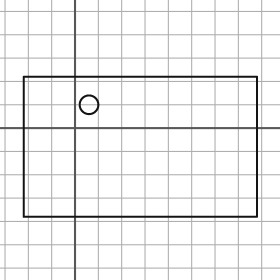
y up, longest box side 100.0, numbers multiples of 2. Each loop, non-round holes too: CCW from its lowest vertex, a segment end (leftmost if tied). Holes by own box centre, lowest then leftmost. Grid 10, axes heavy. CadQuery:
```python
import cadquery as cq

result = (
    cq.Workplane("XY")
    .moveTo(-22.0, -38.0)
    .lineTo(78.0, -38.0)
    .lineTo(78.0, 22.0)
    .lineTo(-22.0, 22.0)
    .close()
    .moveTo(6.0, 10.0)
    .circle(4.0)
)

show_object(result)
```